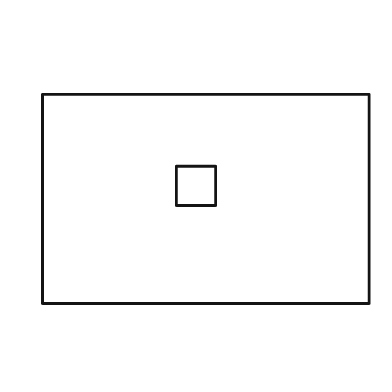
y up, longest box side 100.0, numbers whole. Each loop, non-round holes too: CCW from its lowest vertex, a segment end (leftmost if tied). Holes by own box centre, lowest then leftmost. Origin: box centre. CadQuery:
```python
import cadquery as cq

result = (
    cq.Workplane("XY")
    .moveTo(-50.0, -32.0)
    .lineTo(50.0, -32.0)
    .lineTo(50.0, 32.0)
    .lineTo(-50.0, 32.0)
    .close()
    .moveTo(-9.0, -2.0)
    .lineTo(3.0, -2.0)
    .lineTo(3.0, 10.0)
    .lineTo(-9.0, 10.0)
    .close()
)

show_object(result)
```